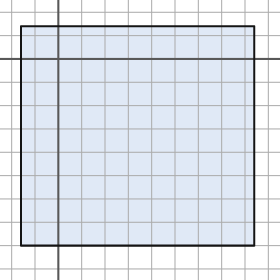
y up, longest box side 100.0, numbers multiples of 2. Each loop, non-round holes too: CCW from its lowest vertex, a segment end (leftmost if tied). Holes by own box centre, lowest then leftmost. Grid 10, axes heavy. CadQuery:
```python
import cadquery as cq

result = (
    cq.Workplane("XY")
    .moveTo(-16.0, -80.0)
    .lineTo(84.0, -80.0)
    .lineTo(84.0, 14.0)
    .lineTo(-16.0, 14.0)
    .close()
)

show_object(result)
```